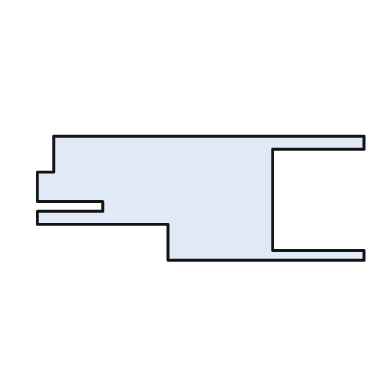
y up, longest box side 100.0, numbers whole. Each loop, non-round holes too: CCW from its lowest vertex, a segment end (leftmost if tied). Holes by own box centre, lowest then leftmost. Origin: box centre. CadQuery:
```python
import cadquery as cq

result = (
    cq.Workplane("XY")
    .moveTo(-10.0, -19.0)
    .lineTo(50.0, -19.0)
    .lineTo(50.0, -16.0)
    .lineTo(22.0, -16.0)
    .lineTo(22.0, 15.0)
    .lineTo(50.0, 15.0)
    .lineTo(50.0, 19.0)
    .lineTo(-45.0, 19.0)
    .lineTo(-45.0, 8.0)
    .lineTo(-50.0, 8.0)
    .lineTo(-50.0, -1.0)
    .lineTo(-30.0, -1.0)
    .lineTo(-30.0, -4.0)
    .lineTo(-50.0, -4.0)
    .lineTo(-50.0, -8.0)
    .lineTo(-10.0, -8.0)
    .close()
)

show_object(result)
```